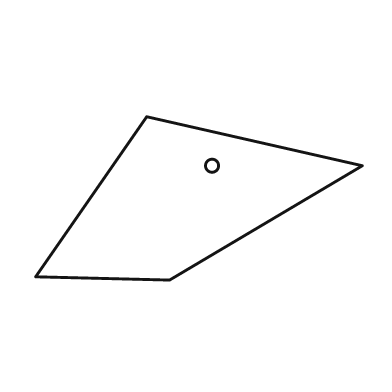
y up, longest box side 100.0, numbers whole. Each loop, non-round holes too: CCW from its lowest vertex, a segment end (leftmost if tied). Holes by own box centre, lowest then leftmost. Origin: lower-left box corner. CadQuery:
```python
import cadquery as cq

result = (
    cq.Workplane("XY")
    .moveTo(41.0, 0.0)
    .lineTo(100.0, 35.0)
    .lineTo(34.0, 50.0)
    .lineTo(0.0, 1.0)
    .close()
    .moveTo(54.0, 35.0)
    .circle(2.0)
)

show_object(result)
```